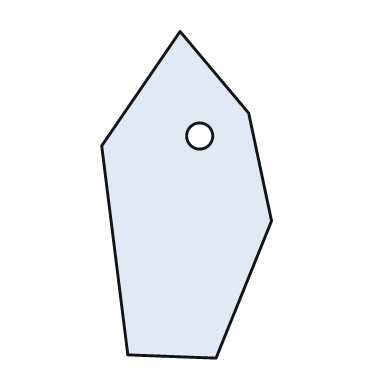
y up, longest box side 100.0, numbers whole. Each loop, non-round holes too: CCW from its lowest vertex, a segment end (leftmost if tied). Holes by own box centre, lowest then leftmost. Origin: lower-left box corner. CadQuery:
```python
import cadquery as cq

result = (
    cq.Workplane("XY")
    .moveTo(35.0, 0.0)
    .lineTo(52.0, 42.0)
    .lineTo(45.0, 75.0)
    .lineTo(24.0, 100.0)
    .lineTo(0.0, 65.0)
    .lineTo(8.0, 1.0)
    .close()
    .moveTo(30.0, 68.0)
    .circle(4.0)
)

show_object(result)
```